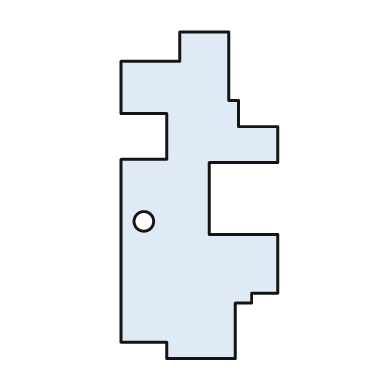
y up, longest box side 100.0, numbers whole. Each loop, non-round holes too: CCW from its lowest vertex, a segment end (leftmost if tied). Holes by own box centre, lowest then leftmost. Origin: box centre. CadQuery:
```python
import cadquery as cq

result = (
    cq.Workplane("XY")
    .moveTo(-10.0, -50.0)
    .lineTo(11.0, -50.0)
    .lineTo(11.0, -33.0)
    .lineTo(16.0, -33.0)
    .lineTo(16.0, -30.0)
    .lineTo(24.0, -30.0)
    .lineTo(24.0, -12.0)
    .lineTo(3.0, -12.0)
    .lineTo(3.0, 10.0)
    .lineTo(24.0, 10.0)
    .lineTo(24.0, 21.0)
    .lineTo(12.0, 21.0)
    .lineTo(12.0, 29.0)
    .lineTo(9.0, 29.0)
    .lineTo(9.0, 50.0)
    .lineTo(-6.0, 50.0)
    .lineTo(-6.0, 41.0)
    .lineTo(-24.0, 41.0)
    .lineTo(-24.0, 25.0)
    .lineTo(-10.0, 25.0)
    .lineTo(-10.0, 11.0)
    .lineTo(-24.0, 11.0)
    .lineTo(-24.0, -45.0)
    .lineTo(-10.0, -45.0)
    .close()
    .moveTo(-17.0, -8.0)
    .circle(3.0)
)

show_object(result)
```